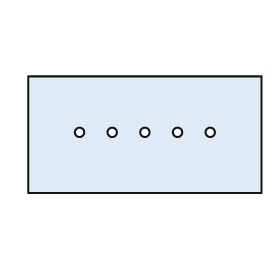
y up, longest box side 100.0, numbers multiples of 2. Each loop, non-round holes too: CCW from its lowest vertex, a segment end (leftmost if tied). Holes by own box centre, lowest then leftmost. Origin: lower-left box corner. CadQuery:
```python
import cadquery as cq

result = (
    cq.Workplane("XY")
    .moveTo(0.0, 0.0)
    .lineTo(100.0, 0.0)
    .lineTo(100.0, 50.0)
    .lineTo(0.0, 50.0)
    .close()
    .moveTo(22.0, 26.0)
    .circle(2.0)
    .moveTo(36.0, 26.0)
    .circle(2.0)
    .moveTo(50.0, 26.0)
    .circle(2.0)
    .moveTo(64.0, 26.0)
    .circle(2.0)
    .moveTo(78.0, 26.0)
    .circle(2.0)
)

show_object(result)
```